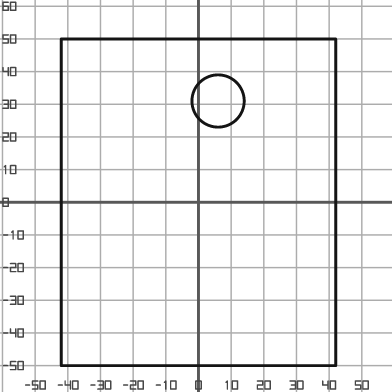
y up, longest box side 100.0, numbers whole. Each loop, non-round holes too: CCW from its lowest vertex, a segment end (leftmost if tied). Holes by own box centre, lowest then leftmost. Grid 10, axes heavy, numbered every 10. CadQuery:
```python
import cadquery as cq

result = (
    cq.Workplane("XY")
    .moveTo(-42.0, -50.0)
    .lineTo(42.0, -50.0)
    .lineTo(42.0, 50.0)
    .lineTo(-42.0, 50.0)
    .close()
    .moveTo(6.0, 31.0)
    .circle(8.0)
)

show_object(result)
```